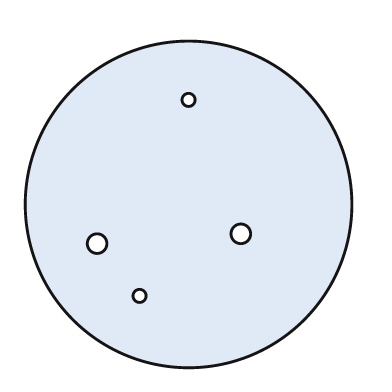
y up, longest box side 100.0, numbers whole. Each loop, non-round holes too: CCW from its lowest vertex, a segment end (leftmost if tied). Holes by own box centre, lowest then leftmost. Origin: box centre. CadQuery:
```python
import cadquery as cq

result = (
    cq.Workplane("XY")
    .moveTo(0.0, 0.0)
    .circle(50.0)
    .moveTo(-15.0, -28.0)
    .circle(2.0)
    .moveTo(-28.0, -12.0)
    .circle(3.0)
    .moveTo(16.0, -9.0)
    .circle(3.0)
    .moveTo(0.0, 32.0)
    .circle(2.0)
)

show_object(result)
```